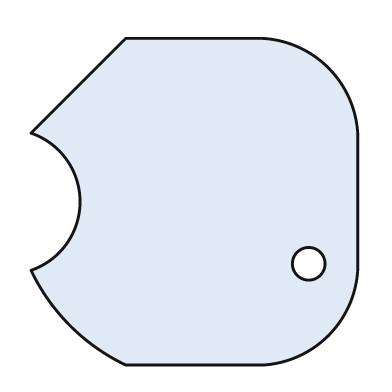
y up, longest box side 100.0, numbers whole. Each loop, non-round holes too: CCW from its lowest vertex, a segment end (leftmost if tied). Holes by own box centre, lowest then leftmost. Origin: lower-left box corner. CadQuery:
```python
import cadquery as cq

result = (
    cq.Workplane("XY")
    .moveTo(29.0, 0.0)
    .lineTo(71.0, 0.0)
    .threePointArc((91.0, 9.0), (100.0, 29.0))
    .lineTo(100.0, 71.0)
    .threePointArc((91.0, 91.0), (71.0, 100.0))
    .lineTo(29.0, 100.0)
    .lineTo(0.0, 71.0)
    .threePointArc((15.0, 50.0), (0.0, 29.0))
    .threePointArc((12.0, 12.0), (29.0, 0.0))
    .close()
    .moveTo(85.0, 31.0)
    .circle(5.0)
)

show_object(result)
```